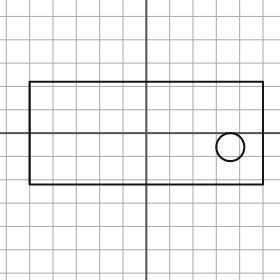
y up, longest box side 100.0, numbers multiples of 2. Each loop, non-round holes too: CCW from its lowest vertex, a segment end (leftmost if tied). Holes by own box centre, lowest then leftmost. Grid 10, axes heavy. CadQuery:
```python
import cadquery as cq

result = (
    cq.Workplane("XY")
    .moveTo(-50.0, -22.0)
    .lineTo(50.0, -22.0)
    .lineTo(50.0, 22.0)
    .lineTo(-50.0, 22.0)
    .close()
    .moveTo(36.0, -6.0)
    .circle(6.0)
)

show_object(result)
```